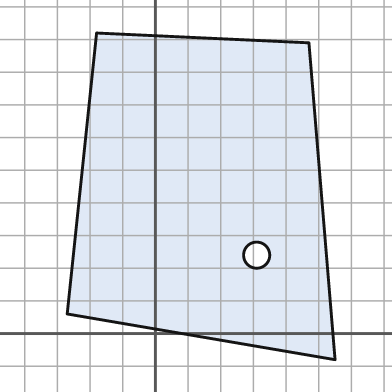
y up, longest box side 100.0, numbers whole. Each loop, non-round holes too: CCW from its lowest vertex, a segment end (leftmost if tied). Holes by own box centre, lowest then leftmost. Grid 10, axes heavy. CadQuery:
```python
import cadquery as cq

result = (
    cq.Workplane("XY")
    .moveTo(55.0, -8.0)
    .lineTo(47.0, 89.0)
    .lineTo(-18.0, 92.0)
    .lineTo(-27.0, 6.0)
    .close()
    .moveTo(31.0, 24.0)
    .circle(4.0)
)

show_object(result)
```